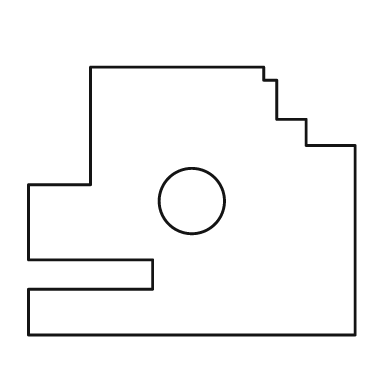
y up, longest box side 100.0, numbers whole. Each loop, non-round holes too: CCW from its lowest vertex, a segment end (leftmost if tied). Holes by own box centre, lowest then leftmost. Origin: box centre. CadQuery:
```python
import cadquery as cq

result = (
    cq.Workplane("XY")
    .moveTo(-50.0, -41.0)
    .lineTo(50.0, -41.0)
    .lineTo(50.0, 17.0)
    .lineTo(35.0, 17.0)
    .lineTo(35.0, 25.0)
    .lineTo(26.0, 25.0)
    .lineTo(26.0, 37.0)
    .lineTo(22.0, 37.0)
    .lineTo(22.0, 41.0)
    .lineTo(-31.0, 41.0)
    .lineTo(-31.0, 5.0)
    .lineTo(-50.0, 5.0)
    .lineTo(-50.0, -18.0)
    .lineTo(-12.0, -18.0)
    .lineTo(-12.0, -27.0)
    .lineTo(-50.0, -27.0)
    .close()
    .moveTo(0.0, 0.0)
    .circle(10.0)
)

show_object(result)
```